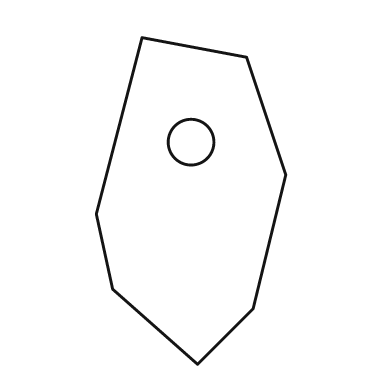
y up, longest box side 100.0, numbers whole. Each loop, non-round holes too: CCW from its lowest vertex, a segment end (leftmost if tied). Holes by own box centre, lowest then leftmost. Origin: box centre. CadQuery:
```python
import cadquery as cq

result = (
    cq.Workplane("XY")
    .moveTo(2.0, -50.0)
    .lineTo(19.0, -33.0)
    .lineTo(29.0, 8.0)
    .lineTo(17.0, 44.0)
    .lineTo(-15.0, 50.0)
    .lineTo(-29.0, -4.0)
    .lineTo(-24.0, -27.0)
    .close()
    .moveTo(0.0, 18.0)
    .circle(7.0)
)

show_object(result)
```